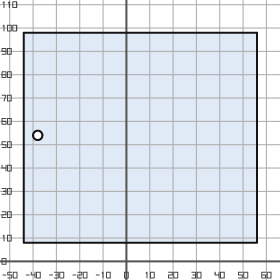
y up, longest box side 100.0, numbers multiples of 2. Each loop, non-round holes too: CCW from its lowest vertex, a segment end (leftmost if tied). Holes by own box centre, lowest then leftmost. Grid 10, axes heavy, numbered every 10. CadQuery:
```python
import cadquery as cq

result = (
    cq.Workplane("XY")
    .moveTo(-44.0, 8.0)
    .lineTo(56.0, 8.0)
    .lineTo(56.0, 98.0)
    .lineTo(-44.0, 98.0)
    .close()
    .moveTo(-38.0, 54.0)
    .circle(2.0)
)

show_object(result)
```